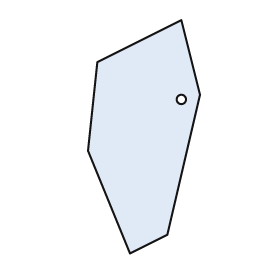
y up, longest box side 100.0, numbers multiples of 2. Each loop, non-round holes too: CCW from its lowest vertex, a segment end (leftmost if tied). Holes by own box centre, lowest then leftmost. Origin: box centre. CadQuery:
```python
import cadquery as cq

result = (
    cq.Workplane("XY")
    .moveTo(-6.0, -50.0)
    .lineTo(10.0, -42.0)
    .lineTo(24.0, 18.0)
    .lineTo(16.0, 50.0)
    .lineTo(-20.0, 32.0)
    .lineTo(-24.0, -6.0)
    .close()
    .moveTo(16.0, 16.0)
    .circle(2.0)
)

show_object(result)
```